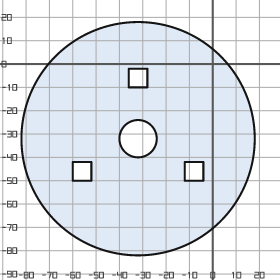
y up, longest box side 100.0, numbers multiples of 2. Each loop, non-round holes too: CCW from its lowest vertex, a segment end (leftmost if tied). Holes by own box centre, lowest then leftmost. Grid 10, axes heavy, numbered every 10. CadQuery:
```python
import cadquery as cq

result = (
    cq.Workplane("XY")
    .moveTo(-32.0, -32.0)
    .circle(50.0)
    .moveTo(-60.0, -50.0)
    .lineTo(-52.0, -50.0)
    .lineTo(-52.0, -42.0)
    .lineTo(-60.0, -42.0)
    .close()
    .moveTo(-12.0, -50.0)
    .lineTo(-4.0, -50.0)
    .lineTo(-4.0, -42.0)
    .lineTo(-12.0, -42.0)
    .close()
    .moveTo(-32.0, -32.0)
    .circle(8.0)
    .moveTo(-36.0, -10.0)
    .lineTo(-28.0, -10.0)
    .lineTo(-28.0, -2.0)
    .lineTo(-36.0, -2.0)
    .close()
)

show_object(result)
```